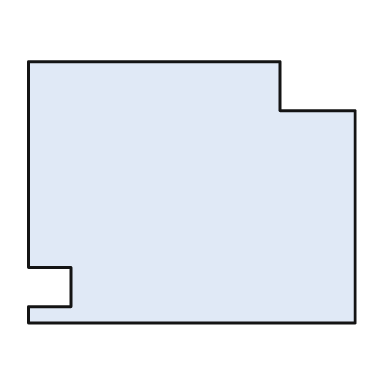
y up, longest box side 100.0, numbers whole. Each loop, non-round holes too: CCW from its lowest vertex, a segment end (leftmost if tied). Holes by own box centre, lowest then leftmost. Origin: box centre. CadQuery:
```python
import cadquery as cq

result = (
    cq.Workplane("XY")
    .moveTo(-50.0, -40.0)
    .lineTo(50.0, -40.0)
    .lineTo(50.0, 25.0)
    .lineTo(27.0, 25.0)
    .lineTo(27.0, 40.0)
    .lineTo(-50.0, 40.0)
    .lineTo(-50.0, -23.0)
    .lineTo(-37.0, -23.0)
    .lineTo(-37.0, -35.0)
    .lineTo(-50.0, -35.0)
    .close()
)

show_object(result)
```